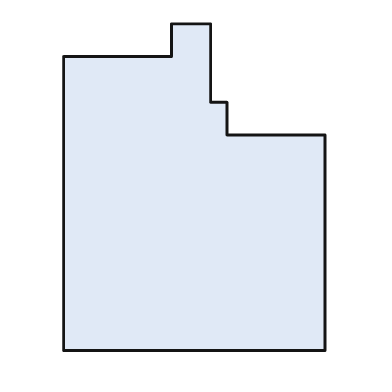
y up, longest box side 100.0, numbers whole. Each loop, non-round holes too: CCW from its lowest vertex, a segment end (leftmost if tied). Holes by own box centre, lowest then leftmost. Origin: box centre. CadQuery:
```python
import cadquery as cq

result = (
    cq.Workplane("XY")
    .moveTo(-40.0, -50.0)
    .lineTo(40.0, -50.0)
    .lineTo(40.0, 16.0)
    .lineTo(10.0, 16.0)
    .lineTo(10.0, 26.0)
    .lineTo(5.0, 26.0)
    .lineTo(5.0, 50.0)
    .lineTo(-7.0, 50.0)
    .lineTo(-7.0, 40.0)
    .lineTo(-40.0, 40.0)
    .close()
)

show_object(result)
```